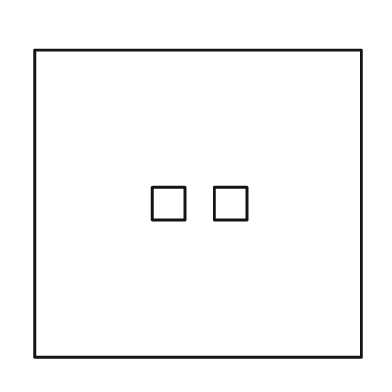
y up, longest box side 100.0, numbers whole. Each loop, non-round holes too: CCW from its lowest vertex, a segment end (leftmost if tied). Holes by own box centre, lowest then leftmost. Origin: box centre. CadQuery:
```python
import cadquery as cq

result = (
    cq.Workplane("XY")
    .moveTo(-50.0, -47.0)
    .lineTo(50.0, -47.0)
    .lineTo(50.0, 47.0)
    .lineTo(-50.0, 47.0)
    .close()
    .moveTo(-14.0, -5.0)
    .lineTo(-4.0, -5.0)
    .lineTo(-4.0, 5.0)
    .lineTo(-14.0, 5.0)
    .close()
    .moveTo(5.0, -5.0)
    .lineTo(15.0, -5.0)
    .lineTo(15.0, 5.0)
    .lineTo(5.0, 5.0)
    .close()
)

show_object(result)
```